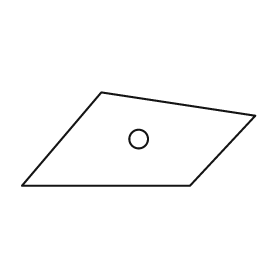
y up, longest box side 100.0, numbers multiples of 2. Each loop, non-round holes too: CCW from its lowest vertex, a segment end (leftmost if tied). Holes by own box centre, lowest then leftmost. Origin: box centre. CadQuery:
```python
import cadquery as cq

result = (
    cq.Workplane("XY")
    .moveTo(-50.0, -20.0)
    .lineTo(22.0, -20.0)
    .lineTo(50.0, 10.0)
    .lineTo(-16.0, 20.0)
    .close()
    .moveTo(0.0, 0.0)
    .circle(4.0)
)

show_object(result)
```